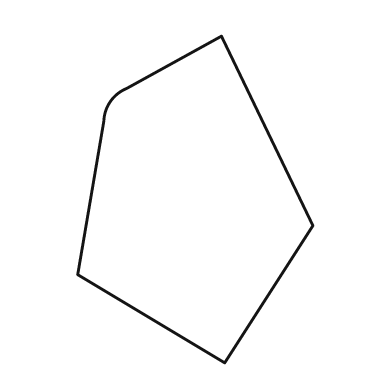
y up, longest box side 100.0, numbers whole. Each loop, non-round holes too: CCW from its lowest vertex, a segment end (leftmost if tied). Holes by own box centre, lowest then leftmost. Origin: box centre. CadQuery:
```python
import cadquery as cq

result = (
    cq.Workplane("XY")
    .moveTo(9.0, -50.0)
    .lineTo(36.0, -8.0)
    .lineTo(8.0, 50.0)
    .lineTo(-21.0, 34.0)
    .threePointArc((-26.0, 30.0), (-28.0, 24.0))
    .lineTo(-36.0, -23.0)
    .close()
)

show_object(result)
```